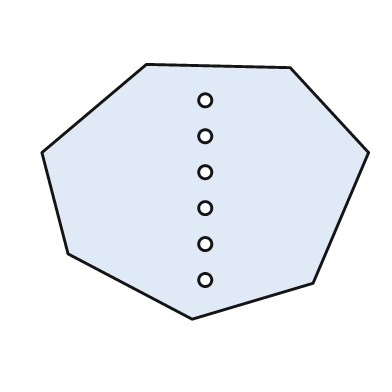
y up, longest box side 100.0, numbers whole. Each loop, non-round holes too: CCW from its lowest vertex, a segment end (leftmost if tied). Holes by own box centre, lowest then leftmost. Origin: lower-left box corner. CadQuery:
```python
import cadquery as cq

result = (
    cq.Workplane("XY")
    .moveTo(46.0, 0.0)
    .lineTo(83.0, 11.0)
    .lineTo(100.0, 51.0)
    .lineTo(76.0, 77.0)
    .lineTo(32.0, 78.0)
    .lineTo(0.0, 51.0)
    .lineTo(8.0, 20.0)
    .close()
    .moveTo(50.0, 12.0)
    .circle(2.0)
    .moveTo(50.0, 23.0)
    .circle(2.0)
    .moveTo(50.0, 34.0)
    .circle(2.0)
    .moveTo(50.0, 45.0)
    .circle(2.0)
    .moveTo(50.0, 56.0)
    .circle(2.0)
    .moveTo(50.0, 67.0)
    .circle(2.0)
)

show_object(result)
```